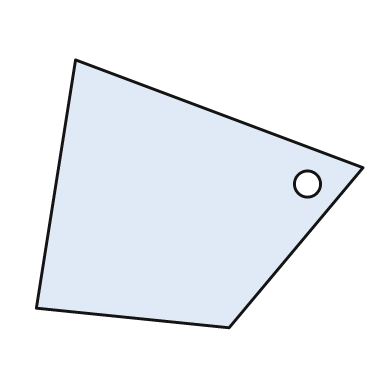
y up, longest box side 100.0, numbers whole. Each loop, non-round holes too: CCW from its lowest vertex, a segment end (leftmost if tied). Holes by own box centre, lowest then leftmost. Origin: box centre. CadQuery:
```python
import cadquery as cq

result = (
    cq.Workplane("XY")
    .moveTo(9.0, -41.0)
    .lineTo(50.0, 8.0)
    .lineTo(-38.0, 41.0)
    .lineTo(-50.0, -35.0)
    .close()
    .moveTo(33.0, 3.0)
    .circle(4.0)
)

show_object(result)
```